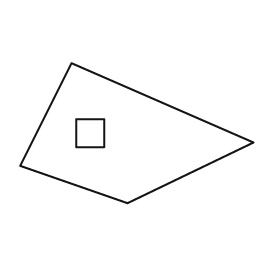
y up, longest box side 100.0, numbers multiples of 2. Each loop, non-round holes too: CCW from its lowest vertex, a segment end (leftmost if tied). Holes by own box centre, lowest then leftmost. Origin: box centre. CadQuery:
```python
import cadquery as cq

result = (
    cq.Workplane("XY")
    .moveTo(-4.0, -30.0)
    .lineTo(50.0, -4.0)
    .lineTo(-28.0, 30.0)
    .lineTo(-50.0, -14.0)
    .close()
    .moveTo(-26.0, -6.0)
    .lineTo(-14.0, -6.0)
    .lineTo(-14.0, 6.0)
    .lineTo(-26.0, 6.0)
    .close()
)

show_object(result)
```